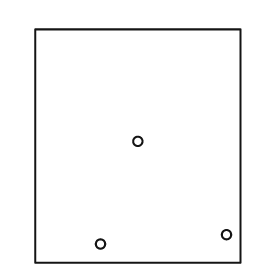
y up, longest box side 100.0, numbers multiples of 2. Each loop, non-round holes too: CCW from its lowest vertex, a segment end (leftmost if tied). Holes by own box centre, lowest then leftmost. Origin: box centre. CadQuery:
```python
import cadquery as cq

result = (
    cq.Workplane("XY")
    .moveTo(-44.0, -50.0)
    .lineTo(44.0, -50.0)
    .lineTo(44.0, 50.0)
    .lineTo(-44.0, 50.0)
    .close()
    .moveTo(-16.0, -42.0)
    .circle(2.0)
    .moveTo(38.0, -38.0)
    .circle(2.0)
    .moveTo(0.0, 2.0)
    .circle(2.0)
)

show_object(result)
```